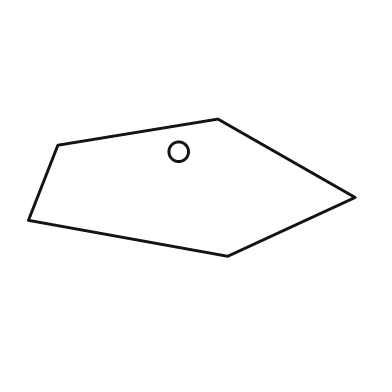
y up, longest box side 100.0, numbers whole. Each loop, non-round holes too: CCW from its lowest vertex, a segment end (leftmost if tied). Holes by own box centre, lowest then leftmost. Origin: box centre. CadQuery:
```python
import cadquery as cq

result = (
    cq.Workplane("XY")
    .moveTo(11.0, -21.0)
    .lineTo(50.0, -3.0)
    .lineTo(8.0, 21.0)
    .lineTo(-41.0, 13.0)
    .lineTo(-50.0, -10.0)
    .close()
    .moveTo(-4.0, 11.0)
    .circle(3.0)
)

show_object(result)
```